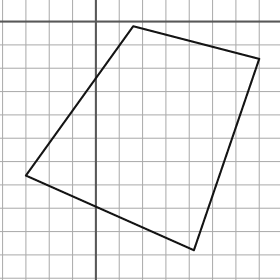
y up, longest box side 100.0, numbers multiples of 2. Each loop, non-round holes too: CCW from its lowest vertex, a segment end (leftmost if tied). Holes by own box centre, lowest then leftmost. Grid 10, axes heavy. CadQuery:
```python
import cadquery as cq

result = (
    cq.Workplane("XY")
    .moveTo(42.0, -98.0)
    .lineTo(70.0, -16.0)
    .lineTo(16.0, -2.0)
    .lineTo(-30.0, -66.0)
    .close()
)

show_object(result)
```